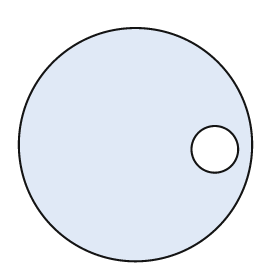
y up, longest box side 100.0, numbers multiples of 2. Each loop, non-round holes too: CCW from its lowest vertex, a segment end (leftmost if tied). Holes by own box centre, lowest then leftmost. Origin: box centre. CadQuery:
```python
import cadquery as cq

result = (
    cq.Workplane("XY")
    .moveTo(0.0, 0.0)
    .circle(50.0)
    .moveTo(34.0, -2.0)
    .circle(10.0)
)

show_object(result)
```